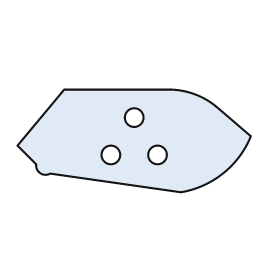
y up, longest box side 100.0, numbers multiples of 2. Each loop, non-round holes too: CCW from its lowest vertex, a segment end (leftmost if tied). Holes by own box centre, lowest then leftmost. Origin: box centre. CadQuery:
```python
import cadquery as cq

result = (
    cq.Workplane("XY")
    .moveTo(20.0, -22.0)
    .threePointArc((38.0, -14.0), (50.0, 2.0))
    .lineTo(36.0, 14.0)
    .threePointArc((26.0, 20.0), (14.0, 22.0))
    .lineTo(-30.0, 22.0)
    .lineTo(-50.0, -2.0)
    .lineTo(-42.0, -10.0)
    .threePointArc((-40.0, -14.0), (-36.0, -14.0))
    .close()
    .moveTo(-10.0, -6.0)
    .circle(4.0)
    .moveTo(10.0, -6.0)
    .circle(4.0)
    .moveTo(0.0, 10.0)
    .circle(4.0)
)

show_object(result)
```